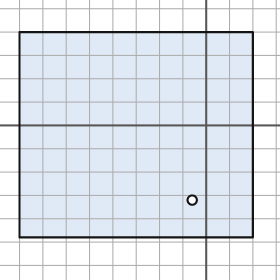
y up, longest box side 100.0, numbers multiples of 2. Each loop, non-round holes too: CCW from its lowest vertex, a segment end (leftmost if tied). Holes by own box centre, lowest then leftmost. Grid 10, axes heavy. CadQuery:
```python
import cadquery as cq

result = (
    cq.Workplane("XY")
    .moveTo(-80.0, -48.0)
    .lineTo(20.0, -48.0)
    .lineTo(20.0, 40.0)
    .lineTo(-80.0, 40.0)
    .close()
    .moveTo(-6.0, -32.0)
    .circle(2.0)
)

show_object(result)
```